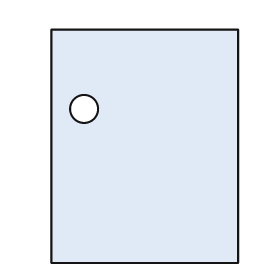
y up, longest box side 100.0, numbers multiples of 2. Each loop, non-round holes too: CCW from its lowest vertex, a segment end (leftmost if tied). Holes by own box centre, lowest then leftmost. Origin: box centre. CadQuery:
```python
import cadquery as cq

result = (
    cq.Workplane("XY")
    .moveTo(-40.0, -50.0)
    .lineTo(40.0, -50.0)
    .lineTo(40.0, 50.0)
    .lineTo(-40.0, 50.0)
    .close()
    .moveTo(-26.0, 16.0)
    .circle(6.0)
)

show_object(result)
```